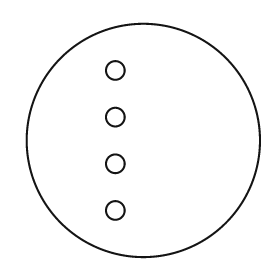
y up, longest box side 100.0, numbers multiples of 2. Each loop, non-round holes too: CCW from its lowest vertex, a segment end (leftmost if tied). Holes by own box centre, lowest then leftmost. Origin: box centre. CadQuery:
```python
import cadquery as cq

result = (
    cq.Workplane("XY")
    .moveTo(0.0, 0.0)
    .circle(50.0)
    .moveTo(-12.0, -30.0)
    .circle(4.0)
    .moveTo(-12.0, -10.0)
    .circle(4.0)
    .moveTo(-12.0, 10.0)
    .circle(4.0)
    .moveTo(-12.0, 30.0)
    .circle(4.0)
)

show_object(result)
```